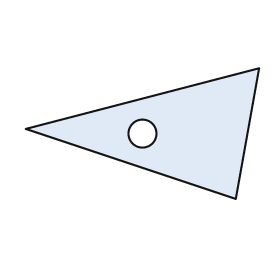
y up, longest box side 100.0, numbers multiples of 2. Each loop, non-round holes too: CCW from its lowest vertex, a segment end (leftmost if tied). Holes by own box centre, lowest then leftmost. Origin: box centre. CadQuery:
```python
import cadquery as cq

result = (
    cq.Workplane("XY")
    .moveTo(40.0, -28.0)
    .lineTo(50.0, 28.0)
    .lineTo(-50.0, 2.0)
    .close()
    .moveTo(0.0, 0.0)
    .circle(6.0)
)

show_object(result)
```